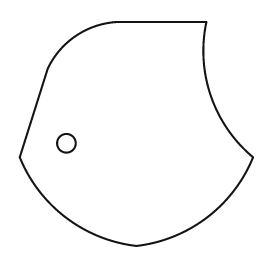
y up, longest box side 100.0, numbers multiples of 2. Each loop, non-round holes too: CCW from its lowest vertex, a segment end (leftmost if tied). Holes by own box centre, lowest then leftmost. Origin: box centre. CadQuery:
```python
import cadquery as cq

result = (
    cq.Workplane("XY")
    .moveTo(0.0, -48.0)
    .threePointArc((30.0, -36.0), (50.0, -10.0))
    .threePointArc((32.0, 16.0), (30.0, 48.0))
    .lineTo(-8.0, 48.0)
    .threePointArc((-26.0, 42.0), (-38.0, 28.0))
    .lineTo(-50.0, -10.0)
    .threePointArc((-30.0, -36.0), (0.0, -48.0))
    .close()
    .moveTo(-30.0, -4.0)
    .circle(4.0)
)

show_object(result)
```